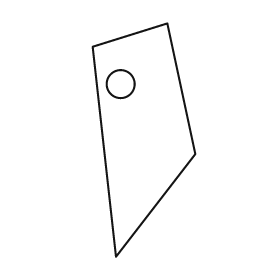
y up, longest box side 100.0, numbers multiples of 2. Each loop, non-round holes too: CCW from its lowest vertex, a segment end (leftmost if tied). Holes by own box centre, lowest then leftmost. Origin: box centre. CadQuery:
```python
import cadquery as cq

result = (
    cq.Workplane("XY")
    .moveTo(-12.0, -50.0)
    .lineTo(22.0, -6.0)
    .lineTo(10.0, 50.0)
    .lineTo(-22.0, 40.0)
    .close()
    .moveTo(-10.0, 24.0)
    .circle(6.0)
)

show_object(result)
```